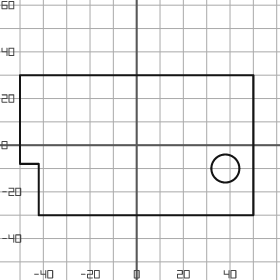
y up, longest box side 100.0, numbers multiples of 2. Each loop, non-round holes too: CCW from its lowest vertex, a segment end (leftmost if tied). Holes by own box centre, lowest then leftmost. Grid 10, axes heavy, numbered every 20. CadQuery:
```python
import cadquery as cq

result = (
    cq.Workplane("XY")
    .moveTo(-42.0, -30.0)
    .lineTo(50.0, -30.0)
    .lineTo(50.0, 30.0)
    .lineTo(-50.0, 30.0)
    .lineTo(-50.0, -8.0)
    .lineTo(-42.0, -8.0)
    .close()
    .moveTo(38.0, -10.0)
    .circle(6.0)
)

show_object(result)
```